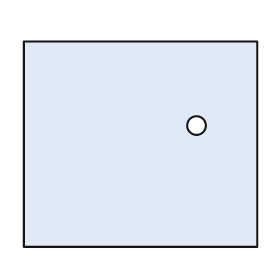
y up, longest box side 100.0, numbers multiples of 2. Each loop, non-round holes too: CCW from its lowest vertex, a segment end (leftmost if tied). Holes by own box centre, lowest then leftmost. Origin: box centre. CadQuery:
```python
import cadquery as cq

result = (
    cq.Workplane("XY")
    .moveTo(-50.0, -44.0)
    .lineTo(50.0, -44.0)
    .lineTo(50.0, 44.0)
    .lineTo(-50.0, 44.0)
    .close()
    .moveTo(24.0, 8.0)
    .circle(4.0)
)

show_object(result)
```